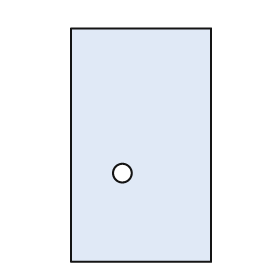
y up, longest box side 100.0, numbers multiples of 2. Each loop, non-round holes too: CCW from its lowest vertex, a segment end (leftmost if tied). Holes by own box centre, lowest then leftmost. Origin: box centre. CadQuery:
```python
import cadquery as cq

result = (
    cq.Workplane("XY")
    .moveTo(-30.0, -50.0)
    .lineTo(30.0, -50.0)
    .lineTo(30.0, 50.0)
    .lineTo(-30.0, 50.0)
    .close()
    .moveTo(-8.0, -12.0)
    .circle(4.0)
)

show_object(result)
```